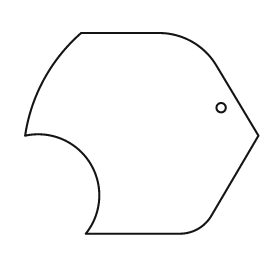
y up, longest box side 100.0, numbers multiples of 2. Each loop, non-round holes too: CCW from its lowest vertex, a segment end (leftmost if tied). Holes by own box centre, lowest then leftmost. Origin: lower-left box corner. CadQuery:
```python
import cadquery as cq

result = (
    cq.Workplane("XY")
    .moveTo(26.0, 0.0)
    .lineTo(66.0, 0.0)
    .threePointArc((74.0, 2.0), (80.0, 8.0))
    .lineTo(100.0, 42.0)
    .lineTo(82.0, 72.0)
    .threePointArc((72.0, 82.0), (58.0, 86.0))
    .lineTo(24.0, 86.0)
    .threePointArc((8.0, 66.0), (0.0, 42.0))
    .threePointArc((28.0, 30.0), (26.0, 0.0))
    .close()
    .moveTo(84.0, 54.0)
    .circle(2.0)
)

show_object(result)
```